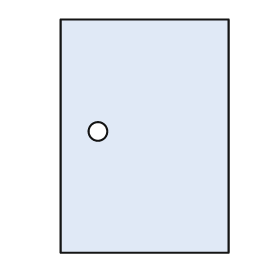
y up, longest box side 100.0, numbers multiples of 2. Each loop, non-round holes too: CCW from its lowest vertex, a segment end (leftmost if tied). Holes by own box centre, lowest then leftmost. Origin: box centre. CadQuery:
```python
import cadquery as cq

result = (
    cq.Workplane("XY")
    .moveTo(-36.0, -50.0)
    .lineTo(36.0, -50.0)
    .lineTo(36.0, 50.0)
    .lineTo(-36.0, 50.0)
    .close()
    .moveTo(-20.0, 2.0)
    .circle(4.0)
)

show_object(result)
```